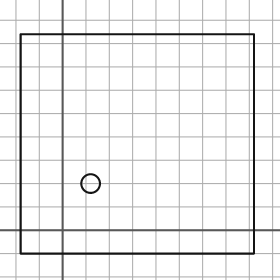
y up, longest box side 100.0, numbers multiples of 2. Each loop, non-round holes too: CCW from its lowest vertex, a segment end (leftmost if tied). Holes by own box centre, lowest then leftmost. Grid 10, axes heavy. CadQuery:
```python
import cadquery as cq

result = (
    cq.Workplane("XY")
    .moveTo(-18.0, -10.0)
    .lineTo(82.0, -10.0)
    .lineTo(82.0, 84.0)
    .lineTo(-18.0, 84.0)
    .close()
    .moveTo(12.0, 20.0)
    .circle(4.0)
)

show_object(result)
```